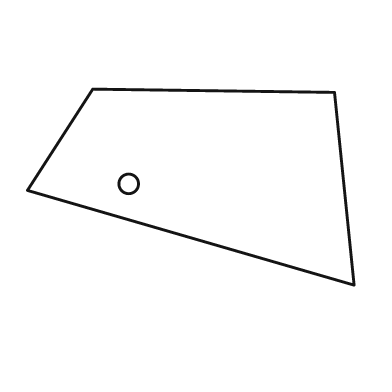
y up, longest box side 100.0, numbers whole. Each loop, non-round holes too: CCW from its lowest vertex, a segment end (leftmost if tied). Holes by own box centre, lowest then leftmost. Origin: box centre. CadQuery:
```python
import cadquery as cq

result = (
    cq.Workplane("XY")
    .moveTo(50.0, -30.0)
    .lineTo(44.0, 29.0)
    .lineTo(-30.0, 30.0)
    .lineTo(-50.0, -1.0)
    .close()
    .moveTo(-19.0, 1.0)
    .circle(3.0)
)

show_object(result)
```